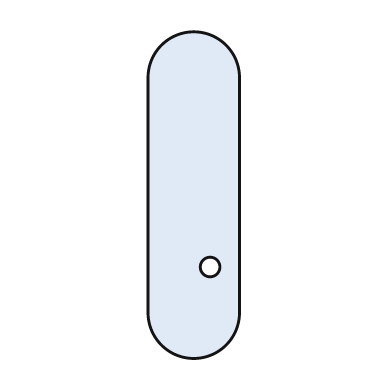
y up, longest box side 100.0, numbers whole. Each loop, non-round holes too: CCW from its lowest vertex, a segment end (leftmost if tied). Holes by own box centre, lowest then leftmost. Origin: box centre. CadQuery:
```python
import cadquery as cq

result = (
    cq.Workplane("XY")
    .moveTo(-14.0, -36.0)
    .threePointArc((0.0, -50.0), (14.0, -36.0))
    .lineTo(14.0, 36.0)
    .threePointArc((0.0, 50.0), (-14.0, 36.0))
    .close()
    .moveTo(5.0, -22.0)
    .circle(3.0)
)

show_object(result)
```